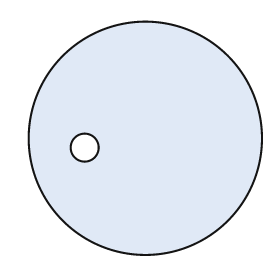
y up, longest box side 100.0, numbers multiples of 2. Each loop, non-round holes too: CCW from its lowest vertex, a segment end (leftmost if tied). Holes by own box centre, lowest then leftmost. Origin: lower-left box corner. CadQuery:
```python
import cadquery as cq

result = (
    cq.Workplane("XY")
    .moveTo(50.0, 50.0)
    .circle(50.0)
    .moveTo(24.0, 46.0)
    .circle(6.0)
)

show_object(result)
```